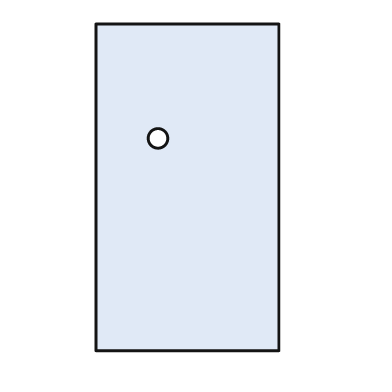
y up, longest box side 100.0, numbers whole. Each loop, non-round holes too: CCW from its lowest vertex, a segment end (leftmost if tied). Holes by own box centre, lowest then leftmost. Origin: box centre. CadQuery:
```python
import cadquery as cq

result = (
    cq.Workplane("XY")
    .moveTo(-28.0, -50.0)
    .lineTo(28.0, -50.0)
    .lineTo(28.0, 50.0)
    .lineTo(-28.0, 50.0)
    .close()
    .moveTo(-9.0, 15.0)
    .circle(3.0)
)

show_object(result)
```